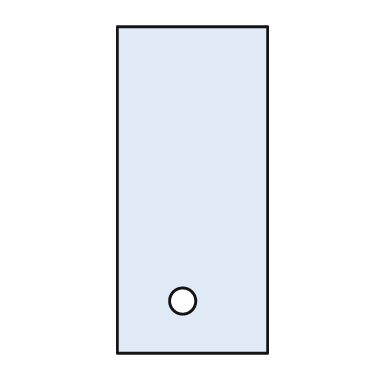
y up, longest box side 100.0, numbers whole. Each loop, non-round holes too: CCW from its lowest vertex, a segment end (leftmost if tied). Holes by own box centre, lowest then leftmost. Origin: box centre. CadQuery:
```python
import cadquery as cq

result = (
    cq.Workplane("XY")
    .moveTo(-23.0, -50.0)
    .lineTo(23.0, -50.0)
    .lineTo(23.0, 50.0)
    .lineTo(-23.0, 50.0)
    .close()
    .moveTo(-3.0, -34.0)
    .circle(4.0)
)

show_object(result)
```